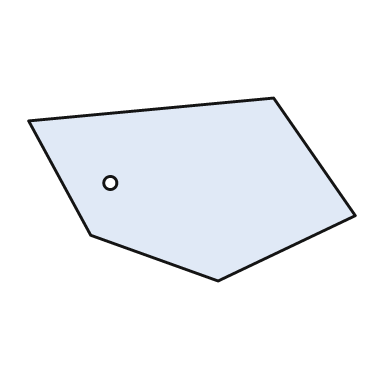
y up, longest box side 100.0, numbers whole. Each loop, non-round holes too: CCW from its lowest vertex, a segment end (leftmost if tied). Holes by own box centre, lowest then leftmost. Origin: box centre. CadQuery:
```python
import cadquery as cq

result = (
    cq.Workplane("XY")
    .moveTo(8.0, -28.0)
    .lineTo(50.0, -8.0)
    .lineTo(25.0, 28.0)
    .lineTo(-50.0, 21.0)
    .lineTo(-31.0, -14.0)
    .close()
    .moveTo(-25.0, 2.0)
    .circle(2.0)
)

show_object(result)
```